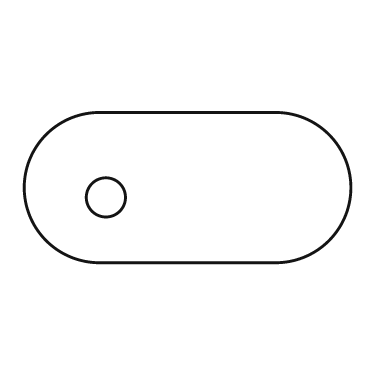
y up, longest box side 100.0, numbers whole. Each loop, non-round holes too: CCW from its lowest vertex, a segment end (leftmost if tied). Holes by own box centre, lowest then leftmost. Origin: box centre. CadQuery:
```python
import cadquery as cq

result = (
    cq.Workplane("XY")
    .moveTo(-27.0, -23.0)
    .lineTo(27.0, -23.0)
    .threePointArc((50.0, 0.0), (27.0, 23.0))
    .lineTo(-27.0, 23.0)
    .threePointArc((-50.0, 0.0), (-27.0, -23.0))
    .close()
    .moveTo(-25.0, -3.0)
    .circle(6.0)
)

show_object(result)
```